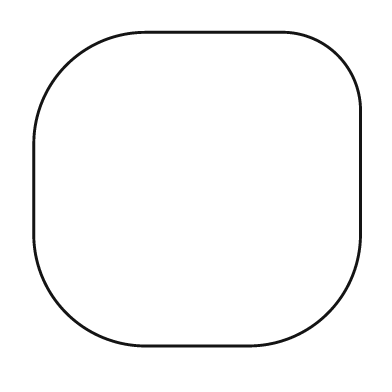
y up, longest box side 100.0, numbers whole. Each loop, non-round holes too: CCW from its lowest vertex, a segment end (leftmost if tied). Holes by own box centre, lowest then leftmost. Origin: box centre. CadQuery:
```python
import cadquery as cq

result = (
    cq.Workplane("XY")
    .moveTo(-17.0, -48.0)
    .lineTo(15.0, -48.0)
    .threePointArc((40.0, -38.0), (50.0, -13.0))
    .lineTo(50.0, 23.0)
    .threePointArc((43.0, 41.0), (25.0, 48.0))
    .lineTo(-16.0, 48.0)
    .threePointArc((-40.0, 38.0), (-50.0, 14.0))
    .lineTo(-50.0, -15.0)
    .threePointArc((-40.0, -38.0), (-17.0, -48.0))
    .close()
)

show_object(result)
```